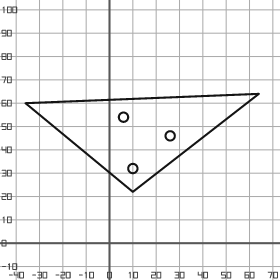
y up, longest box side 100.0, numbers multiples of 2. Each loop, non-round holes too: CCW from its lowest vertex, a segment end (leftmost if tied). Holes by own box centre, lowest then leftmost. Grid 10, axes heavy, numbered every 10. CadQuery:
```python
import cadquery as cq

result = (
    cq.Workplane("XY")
    .moveTo(10.0, 22.0)
    .lineTo(64.0, 64.0)
    .lineTo(-36.0, 60.0)
    .close()
    .moveTo(10.0, 32.0)
    .circle(2.0)
    .moveTo(26.0, 46.0)
    .circle(2.0)
    .moveTo(6.0, 54.0)
    .circle(2.0)
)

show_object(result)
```